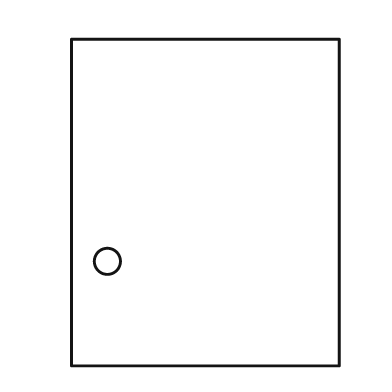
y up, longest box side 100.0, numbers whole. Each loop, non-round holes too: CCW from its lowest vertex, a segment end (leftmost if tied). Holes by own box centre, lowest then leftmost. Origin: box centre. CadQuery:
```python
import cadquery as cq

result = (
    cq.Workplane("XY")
    .moveTo(-41.0, -50.0)
    .lineTo(41.0, -50.0)
    .lineTo(41.0, 50.0)
    .lineTo(-41.0, 50.0)
    .close()
    .moveTo(-30.0, -18.0)
    .circle(4.0)
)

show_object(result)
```